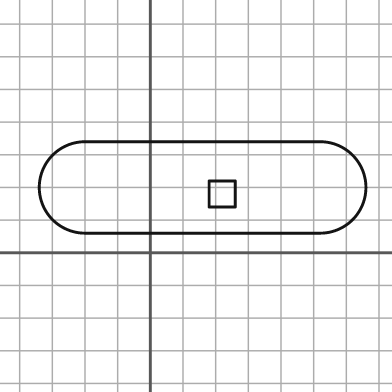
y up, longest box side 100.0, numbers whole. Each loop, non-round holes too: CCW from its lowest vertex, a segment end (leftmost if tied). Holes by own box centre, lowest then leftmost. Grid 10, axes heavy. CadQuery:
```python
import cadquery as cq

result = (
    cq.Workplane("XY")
    .moveTo(-20.0, 6.0)
    .lineTo(52.0, 6.0)
    .threePointArc((66.0, 20.0), (52.0, 34.0))
    .lineTo(-20.0, 34.0)
    .threePointArc((-34.0, 20.0), (-20.0, 6.0))
    .close()
    .moveTo(18.0, 14.0)
    .lineTo(26.0, 14.0)
    .lineTo(26.0, 22.0)
    .lineTo(18.0, 22.0)
    .close()
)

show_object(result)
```